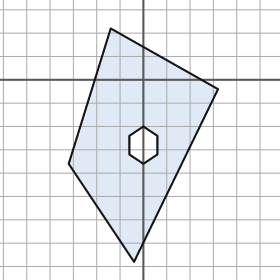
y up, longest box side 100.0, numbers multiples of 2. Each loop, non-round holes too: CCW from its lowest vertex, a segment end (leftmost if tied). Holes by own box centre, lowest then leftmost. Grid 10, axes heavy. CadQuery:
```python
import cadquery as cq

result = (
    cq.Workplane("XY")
    .moveTo(-4.0, -78.0)
    .lineTo(32.0, -4.0)
    .lineTo(-14.0, 22.0)
    .lineTo(-32.0, -36.0)
    .close()
    .moveTo(0.0, -36.0)
    .lineTo(6.0, -32.0)
    .lineTo(6.0, -24.0)
    .lineTo(0.0, -20.0)
    .lineTo(-6.0, -24.0)
    .lineTo(-6.0, -32.0)
    .close()
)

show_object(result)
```